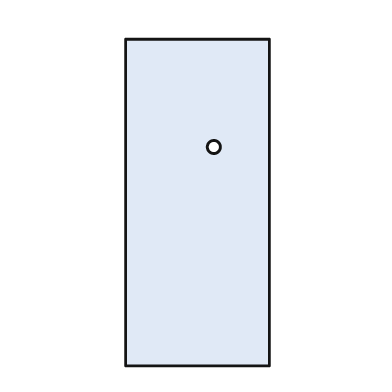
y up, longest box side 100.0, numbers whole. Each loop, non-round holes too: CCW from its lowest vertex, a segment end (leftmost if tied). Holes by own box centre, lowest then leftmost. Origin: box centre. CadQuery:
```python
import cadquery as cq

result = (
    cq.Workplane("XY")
    .moveTo(-22.0, -50.0)
    .lineTo(22.0, -50.0)
    .lineTo(22.0, 50.0)
    .lineTo(-22.0, 50.0)
    .close()
    .moveTo(5.0, 17.0)
    .circle(2.0)
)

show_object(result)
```